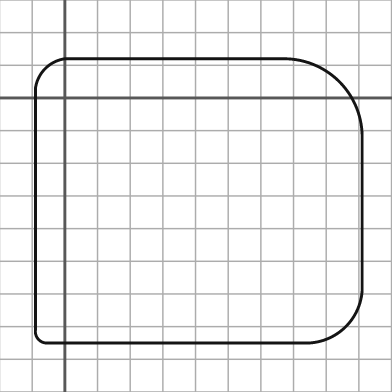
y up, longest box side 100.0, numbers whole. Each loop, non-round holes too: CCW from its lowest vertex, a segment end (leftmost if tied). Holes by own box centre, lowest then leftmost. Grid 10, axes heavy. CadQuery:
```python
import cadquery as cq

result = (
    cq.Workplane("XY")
    .moveTo(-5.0, -75.0)
    .lineTo(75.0, -75.0)
    .threePointArc((86.0, -70.0), (91.0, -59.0))
    .lineTo(91.0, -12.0)
    .threePointArc((84.0, 5.0), (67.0, 12.0))
    .lineTo(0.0, 12.0)
    .threePointArc((-6.0, 9.0), (-9.0, 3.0))
    .lineTo(-9.0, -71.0)
    .threePointArc((-8.0, -74.0), (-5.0, -75.0))
    .close()
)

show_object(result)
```